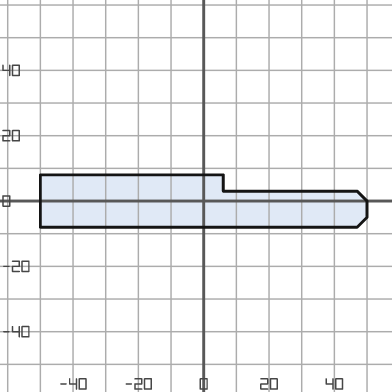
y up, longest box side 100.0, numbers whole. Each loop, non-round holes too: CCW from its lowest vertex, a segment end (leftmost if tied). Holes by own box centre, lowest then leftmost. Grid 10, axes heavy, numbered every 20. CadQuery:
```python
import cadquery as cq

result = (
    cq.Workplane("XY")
    .moveTo(-50.0, -8.0)
    .lineTo(47.0, -8.0)
    .lineTo(50.0, -5.0)
    .lineTo(50.0, 0.0)
    .lineTo(47.0, 3.0)
    .lineTo(6.0, 3.0)
    .lineTo(6.0, 8.0)
    .lineTo(-50.0, 8.0)
    .close()
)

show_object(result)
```